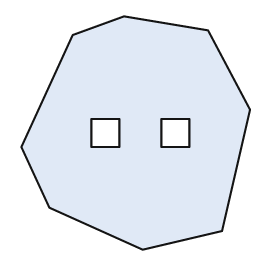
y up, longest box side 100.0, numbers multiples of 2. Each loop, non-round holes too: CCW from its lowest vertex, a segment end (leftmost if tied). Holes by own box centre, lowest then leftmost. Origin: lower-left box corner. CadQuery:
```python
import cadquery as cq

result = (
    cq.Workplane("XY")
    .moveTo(52.0, 0.0)
    .lineTo(86.0, 8.0)
    .lineTo(98.0, 60.0)
    .lineTo(80.0, 94.0)
    .lineTo(44.0, 100.0)
    .lineTo(22.0, 92.0)
    .lineTo(0.0, 44.0)
    .lineTo(12.0, 18.0)
    .close()
    .moveTo(30.0, 44.0)
    .lineTo(42.0, 44.0)
    .lineTo(42.0, 56.0)
    .lineTo(30.0, 56.0)
    .close()
    .moveTo(60.0, 44.0)
    .lineTo(72.0, 44.0)
    .lineTo(72.0, 56.0)
    .lineTo(60.0, 56.0)
    .close()
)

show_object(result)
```